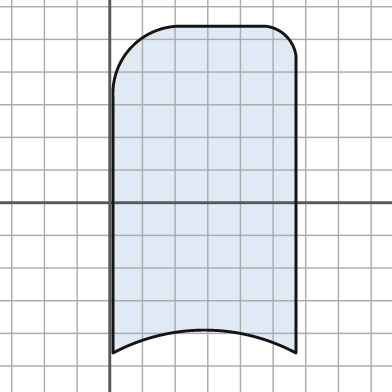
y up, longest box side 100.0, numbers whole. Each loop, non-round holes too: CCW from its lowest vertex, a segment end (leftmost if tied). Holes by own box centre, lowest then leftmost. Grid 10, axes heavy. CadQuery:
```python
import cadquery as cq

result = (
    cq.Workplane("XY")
    .moveTo(1.0, -46.0)
    .threePointArc((29.0, -39.0), (57.0, -46.0))
    .lineTo(57.0, 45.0)
    .threePointArc((54.0, 51.0), (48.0, 54.0))
    .lineTo(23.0, 54.0)
    .threePointArc((7.0, 48.0), (1.0, 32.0))
    .close()
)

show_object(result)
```